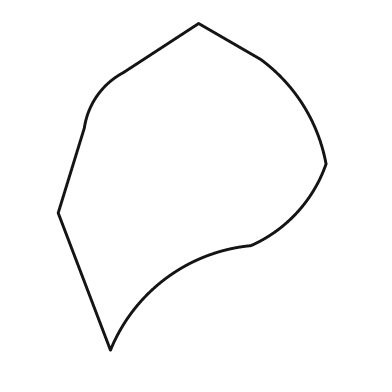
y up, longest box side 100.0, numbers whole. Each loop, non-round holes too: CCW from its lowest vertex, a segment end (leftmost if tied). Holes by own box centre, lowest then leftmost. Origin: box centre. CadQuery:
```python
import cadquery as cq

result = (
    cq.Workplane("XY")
    .moveTo(-25.0, -50.0)
    .threePointArc((-8.0, -28.0), (18.0, -18.0))
    .threePointArc((32.0, -8.0), (41.0, 7.0))
    .threePointArc((34.0, 25.0), (21.0, 39.0))
    .lineTo(2.0, 50.0)
    .lineTo(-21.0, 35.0)
    .threePointArc((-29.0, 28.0), (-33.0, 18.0))
    .lineTo(-41.0, -8.0)
    .close()
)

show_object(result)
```